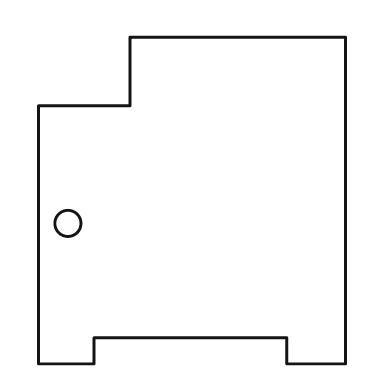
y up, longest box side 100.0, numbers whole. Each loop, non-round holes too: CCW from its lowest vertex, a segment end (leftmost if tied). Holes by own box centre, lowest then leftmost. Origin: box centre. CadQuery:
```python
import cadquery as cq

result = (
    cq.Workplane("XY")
    .moveTo(-47.0, -50.0)
    .lineTo(-30.0, -50.0)
    .lineTo(-30.0, -42.0)
    .lineTo(29.0, -42.0)
    .lineTo(29.0, -50.0)
    .lineTo(47.0, -50.0)
    .lineTo(47.0, 50.0)
    .lineTo(-19.0, 50.0)
    .lineTo(-19.0, 29.0)
    .lineTo(-47.0, 29.0)
    .close()
    .moveTo(-38.0, -7.0)
    .circle(4.0)
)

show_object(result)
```